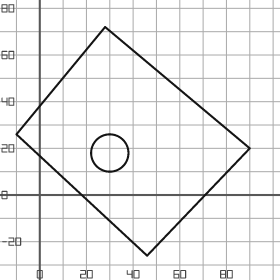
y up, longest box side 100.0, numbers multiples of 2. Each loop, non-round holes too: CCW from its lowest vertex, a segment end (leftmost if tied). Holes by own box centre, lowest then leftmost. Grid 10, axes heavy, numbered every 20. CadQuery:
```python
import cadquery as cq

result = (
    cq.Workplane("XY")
    .moveTo(46.0, -26.0)
    .lineTo(90.0, 20.0)
    .lineTo(28.0, 72.0)
    .lineTo(-10.0, 26.0)
    .close()
    .moveTo(30.0, 18.0)
    .circle(8.0)
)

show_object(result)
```